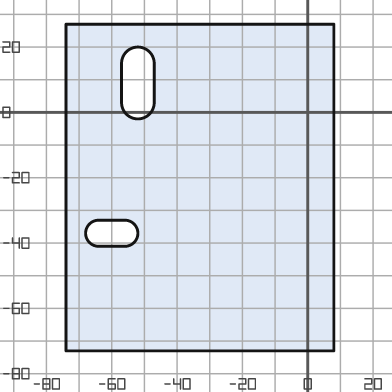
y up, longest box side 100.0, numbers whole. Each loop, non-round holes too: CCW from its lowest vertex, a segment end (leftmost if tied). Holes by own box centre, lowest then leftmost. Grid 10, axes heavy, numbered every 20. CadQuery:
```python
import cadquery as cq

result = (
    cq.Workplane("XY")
    .moveTo(-74.0, -73.0)
    .lineTo(8.0, -73.0)
    .lineTo(8.0, 27.0)
    .lineTo(-74.0, 27.0)
    .close()
    .moveTo(-64.0, -41.0)
    .lineTo(-56.0, -41.0)
    .threePointArc((-52.0, -37.0), (-56.0, -33.0))
    .lineTo(-64.0, -33.0)
    .threePointArc((-68.0, -37.0), (-64.0, -41.0))
    .close()
    .moveTo(-57.0, 3.0)
    .threePointArc((-52.0, -2.0), (-47.0, 3.0))
    .lineTo(-47.0, 15.0)
    .threePointArc((-52.0, 20.0), (-57.0, 15.0))
    .close()
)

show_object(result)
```